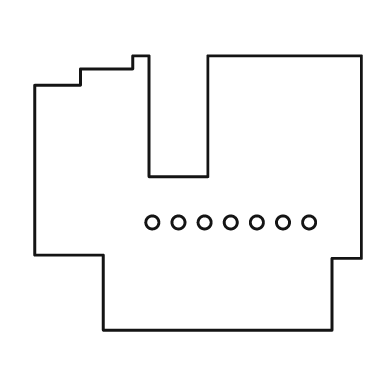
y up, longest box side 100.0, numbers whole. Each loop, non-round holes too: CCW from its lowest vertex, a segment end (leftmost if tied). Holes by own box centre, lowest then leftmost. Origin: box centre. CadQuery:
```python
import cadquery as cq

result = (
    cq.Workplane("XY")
    .moveTo(-29.0, -42.0)
    .lineTo(41.0, -42.0)
    .lineTo(41.0, -20.0)
    .lineTo(50.0, -20.0)
    .lineTo(50.0, 42.0)
    .lineTo(3.0, 42.0)
    .lineTo(3.0, 5.0)
    .lineTo(-15.0, 5.0)
    .lineTo(-15.0, 42.0)
    .lineTo(-20.0, 42.0)
    .lineTo(-20.0, 38.0)
    .lineTo(-36.0, 38.0)
    .lineTo(-36.0, 33.0)
    .lineTo(-50.0, 33.0)
    .lineTo(-50.0, -19.0)
    .lineTo(-29.0, -19.0)
    .close()
    .moveTo(-14.0, -9.0)
    .circle(2.0)
    .moveTo(-6.0, -9.0)
    .circle(2.0)
    .moveTo(2.0, -9.0)
    .circle(2.0)
    .moveTo(10.0, -9.0)
    .circle(2.0)
    .moveTo(18.0, -9.0)
    .circle(2.0)
    .moveTo(26.0, -9.0)
    .circle(2.0)
    .moveTo(34.0, -9.0)
    .circle(2.0)
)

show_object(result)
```